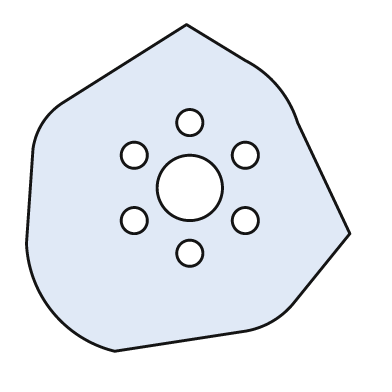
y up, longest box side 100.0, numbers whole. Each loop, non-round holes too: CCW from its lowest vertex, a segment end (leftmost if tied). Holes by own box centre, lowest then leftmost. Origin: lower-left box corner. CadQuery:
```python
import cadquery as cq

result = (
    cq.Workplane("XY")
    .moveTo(27.0, 0.0)
    .lineTo(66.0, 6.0)
    .threePointArc((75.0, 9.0), (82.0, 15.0))
    .lineTo(99.0, 36.0)
    .lineTo(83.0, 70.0)
    .threePointArc((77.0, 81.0), (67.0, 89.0))
    .lineTo(49.0, 100.0)
    .lineTo(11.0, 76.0)
    .threePointArc((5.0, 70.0), (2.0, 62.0))
    .lineTo(0.0, 33.0)
    .threePointArc((8.0, 12.0), (27.0, 0.0))
    .close()
    .moveTo(50.0, 30.0)
    .circle(4.0)
    .moveTo(33.0, 40.0)
    .circle(4.0)
    .moveTo(67.0, 40.0)
    .circle(4.0)
    .moveTo(50.0, 50.0)
    .circle(10.0)
    .moveTo(33.0, 60.0)
    .circle(4.0)
    .moveTo(67.0, 60.0)
    .circle(4.0)
    .moveTo(50.0, 70.0)
    .circle(4.0)
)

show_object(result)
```